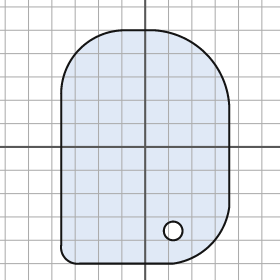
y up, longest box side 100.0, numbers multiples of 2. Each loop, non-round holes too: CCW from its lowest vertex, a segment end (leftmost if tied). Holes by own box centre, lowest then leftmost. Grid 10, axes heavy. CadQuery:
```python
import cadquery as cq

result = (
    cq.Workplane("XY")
    .moveTo(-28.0, -50.0)
    .lineTo(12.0, -50.0)
    .threePointArc((28.0, -42.0), (36.0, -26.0))
    .lineTo(36.0, 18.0)
    .threePointArc((26.0, 40.0), (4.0, 50.0))
    .lineTo(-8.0, 50.0)
    .threePointArc((-28.0, 42.0), (-36.0, 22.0))
    .lineTo(-36.0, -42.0)
    .threePointArc((-34.0, -48.0), (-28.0, -50.0))
    .close()
    .moveTo(12.0, -36.0)
    .circle(4.0)
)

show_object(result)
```